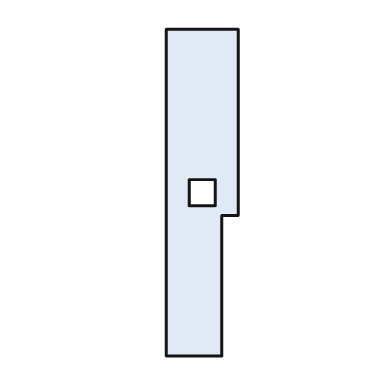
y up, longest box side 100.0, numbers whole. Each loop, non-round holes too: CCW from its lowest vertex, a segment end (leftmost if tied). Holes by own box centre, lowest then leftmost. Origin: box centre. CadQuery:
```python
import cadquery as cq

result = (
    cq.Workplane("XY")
    .moveTo(-11.0, -50.0)
    .lineTo(6.0, -50.0)
    .lineTo(6.0, -7.0)
    .lineTo(11.0, -7.0)
    .lineTo(11.0, 50.0)
    .lineTo(-11.0, 50.0)
    .close()
    .moveTo(-4.0, -4.0)
    .lineTo(4.0, -4.0)
    .lineTo(4.0, 4.0)
    .lineTo(-4.0, 4.0)
    .close()
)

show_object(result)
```